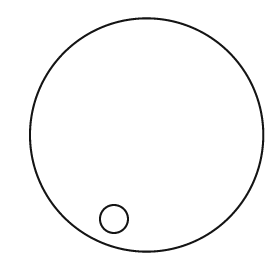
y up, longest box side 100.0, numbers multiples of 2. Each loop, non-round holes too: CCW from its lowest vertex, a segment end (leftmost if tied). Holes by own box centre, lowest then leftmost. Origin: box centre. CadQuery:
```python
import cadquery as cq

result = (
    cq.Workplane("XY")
    .moveTo(0.0, 0.0)
    .circle(50.0)
    .moveTo(-14.0, -36.0)
    .circle(6.0)
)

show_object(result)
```